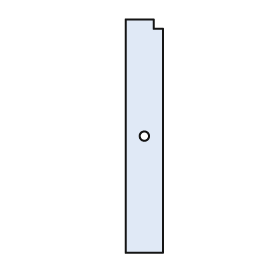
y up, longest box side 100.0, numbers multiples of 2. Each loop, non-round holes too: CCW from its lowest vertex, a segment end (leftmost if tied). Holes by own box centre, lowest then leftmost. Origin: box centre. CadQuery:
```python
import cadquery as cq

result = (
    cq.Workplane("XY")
    .moveTo(-8.0, -50.0)
    .lineTo(8.0, -50.0)
    .lineTo(8.0, 46.0)
    .lineTo(4.0, 46.0)
    .lineTo(4.0, 50.0)
    .lineTo(-8.0, 50.0)
    .close()
    .moveTo(0.0, 0.0)
    .circle(2.0)
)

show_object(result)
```